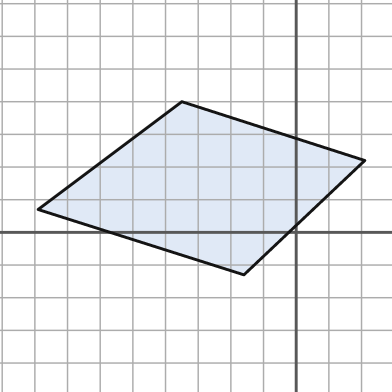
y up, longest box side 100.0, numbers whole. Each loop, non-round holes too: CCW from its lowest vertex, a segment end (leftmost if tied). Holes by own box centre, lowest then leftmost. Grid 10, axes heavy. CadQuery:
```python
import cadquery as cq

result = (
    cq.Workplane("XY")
    .moveTo(-16.0, -13.0)
    .lineTo(21.0, 22.0)
    .lineTo(-35.0, 40.0)
    .lineTo(-79.0, 7.0)
    .close()
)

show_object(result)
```